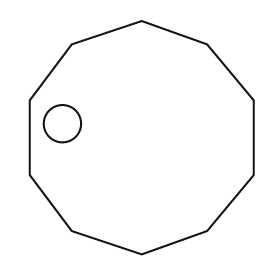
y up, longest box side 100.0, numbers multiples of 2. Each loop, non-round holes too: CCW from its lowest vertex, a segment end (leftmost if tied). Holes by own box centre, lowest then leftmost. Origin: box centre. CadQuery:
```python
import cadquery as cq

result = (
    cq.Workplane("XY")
    .moveTo(0.0, -50.0)
    .lineTo(28.0, -40.0)
    .lineTo(48.0, -16.0)
    .lineTo(48.0, 16.0)
    .lineTo(28.0, 40.0)
    .lineTo(0.0, 50.0)
    .lineTo(-30.0, 40.0)
    .lineTo(-48.0, 16.0)
    .lineTo(-48.0, -16.0)
    .lineTo(-30.0, -40.0)
    .close()
    .moveTo(-34.0, 6.0)
    .circle(8.0)
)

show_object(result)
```